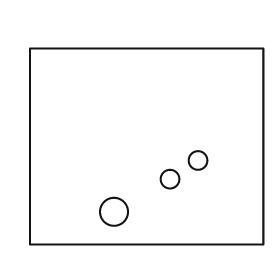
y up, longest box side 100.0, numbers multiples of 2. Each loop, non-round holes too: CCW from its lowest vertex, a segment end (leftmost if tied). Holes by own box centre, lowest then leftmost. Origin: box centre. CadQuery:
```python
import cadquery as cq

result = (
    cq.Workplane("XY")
    .moveTo(-50.0, -42.0)
    .lineTo(50.0, -42.0)
    .lineTo(50.0, 42.0)
    .lineTo(-50.0, 42.0)
    .close()
    .moveTo(-14.0, -28.0)
    .circle(6.0)
    .moveTo(10.0, -14.0)
    .circle(4.0)
    .moveTo(22.0, -6.0)
    .circle(4.0)
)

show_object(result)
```